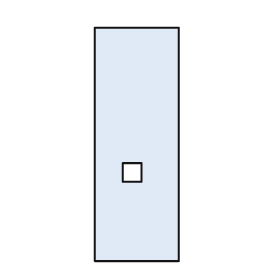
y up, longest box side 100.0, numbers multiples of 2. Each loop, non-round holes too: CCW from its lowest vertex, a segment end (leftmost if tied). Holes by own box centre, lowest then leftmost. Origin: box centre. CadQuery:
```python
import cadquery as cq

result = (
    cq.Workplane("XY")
    .moveTo(-18.0, -50.0)
    .lineTo(18.0, -50.0)
    .lineTo(18.0, 50.0)
    .lineTo(-18.0, 50.0)
    .close()
    .moveTo(-6.0, -16.0)
    .lineTo(2.0, -16.0)
    .lineTo(2.0, -8.0)
    .lineTo(-6.0, -8.0)
    .close()
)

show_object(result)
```